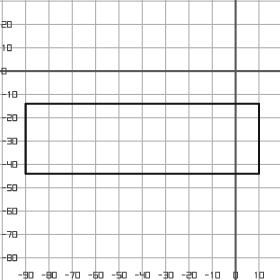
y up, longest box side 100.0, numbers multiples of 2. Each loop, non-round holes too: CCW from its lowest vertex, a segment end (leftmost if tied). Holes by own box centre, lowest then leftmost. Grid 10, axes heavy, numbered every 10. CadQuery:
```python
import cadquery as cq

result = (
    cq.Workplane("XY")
    .moveTo(-90.0, -44.0)
    .lineTo(10.0, -44.0)
    .lineTo(10.0, -14.0)
    .lineTo(-90.0, -14.0)
    .close()
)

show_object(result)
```